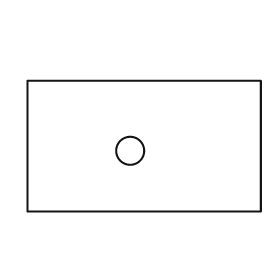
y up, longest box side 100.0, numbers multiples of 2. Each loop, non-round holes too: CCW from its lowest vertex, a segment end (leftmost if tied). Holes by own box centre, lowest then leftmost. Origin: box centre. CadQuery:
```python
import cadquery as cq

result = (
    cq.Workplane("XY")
    .moveTo(-50.0, -28.0)
    .lineTo(50.0, -28.0)
    .lineTo(50.0, 28.0)
    .lineTo(-50.0, 28.0)
    .close()
    .moveTo(-6.0, -2.0)
    .circle(6.0)
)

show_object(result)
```